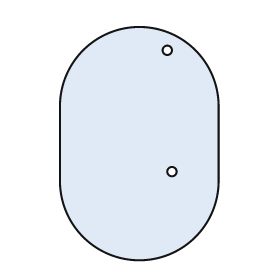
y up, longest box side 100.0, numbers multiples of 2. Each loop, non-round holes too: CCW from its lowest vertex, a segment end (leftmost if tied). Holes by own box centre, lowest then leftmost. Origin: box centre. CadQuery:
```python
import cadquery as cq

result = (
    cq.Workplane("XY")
    .moveTo(-34.0, -16.0)
    .threePointArc((0.0, -50.0), (34.0, -16.0))
    .lineTo(34.0, 16.0)
    .threePointArc((0.0, 50.0), (-34.0, 16.0))
    .close()
    .moveTo(14.0, -12.0)
    .circle(2.0)
    .moveTo(12.0, 40.0)
    .circle(2.0)
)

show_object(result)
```